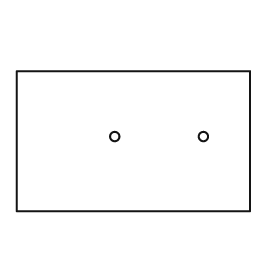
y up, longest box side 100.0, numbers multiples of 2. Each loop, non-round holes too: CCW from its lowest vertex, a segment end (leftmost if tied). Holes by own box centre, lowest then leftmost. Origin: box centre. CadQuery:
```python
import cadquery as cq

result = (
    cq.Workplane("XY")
    .moveTo(-50.0, -30.0)
    .lineTo(50.0, -30.0)
    .lineTo(50.0, 30.0)
    .lineTo(-50.0, 30.0)
    .close()
    .moveTo(-8.0, 2.0)
    .circle(2.0)
    .moveTo(30.0, 2.0)
    .circle(2.0)
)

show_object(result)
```